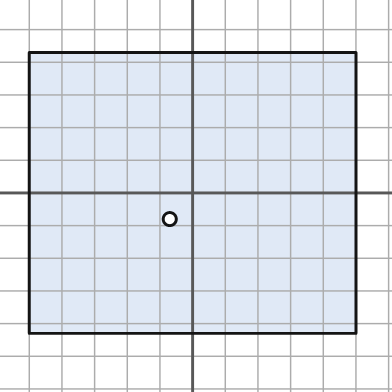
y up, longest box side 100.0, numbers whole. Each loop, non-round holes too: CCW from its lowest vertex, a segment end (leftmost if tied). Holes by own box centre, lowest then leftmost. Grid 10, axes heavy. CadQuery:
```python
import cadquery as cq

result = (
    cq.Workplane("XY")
    .moveTo(-50.0, -43.0)
    .lineTo(50.0, -43.0)
    .lineTo(50.0, 43.0)
    .lineTo(-50.0, 43.0)
    .close()
    .moveTo(-7.0, -8.0)
    .circle(2.0)
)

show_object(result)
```